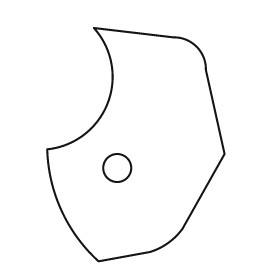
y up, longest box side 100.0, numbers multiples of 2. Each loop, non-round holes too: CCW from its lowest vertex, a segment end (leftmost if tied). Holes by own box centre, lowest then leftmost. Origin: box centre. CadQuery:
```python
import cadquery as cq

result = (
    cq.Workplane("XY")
    .moveTo(-16.0, -50.0)
    .lineTo(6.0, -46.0)
    .threePointArc((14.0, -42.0), (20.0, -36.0))
    .lineTo(38.0, -4.0)
    .lineTo(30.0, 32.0)
    .threePointArc((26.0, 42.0), (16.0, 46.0))
    .lineTo(-18.0, 50.0)
    .threePointArc((-12.0, 18.0), (-38.0, -2.0))
    .threePointArc((-32.0, -28.0), (-16.0, -50.0))
    .close()
    .moveTo(-8.0, -10.0)
    .circle(6.0)
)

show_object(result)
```